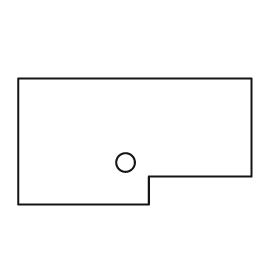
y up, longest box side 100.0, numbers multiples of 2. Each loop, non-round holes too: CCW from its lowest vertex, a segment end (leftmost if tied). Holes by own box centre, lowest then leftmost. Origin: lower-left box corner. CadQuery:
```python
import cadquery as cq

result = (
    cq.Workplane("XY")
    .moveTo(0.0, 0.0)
    .lineTo(56.0, 0.0)
    .lineTo(56.0, 12.0)
    .lineTo(100.0, 12.0)
    .lineTo(100.0, 54.0)
    .lineTo(0.0, 54.0)
    .close()
    .moveTo(46.0, 18.0)
    .circle(4.0)
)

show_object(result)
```